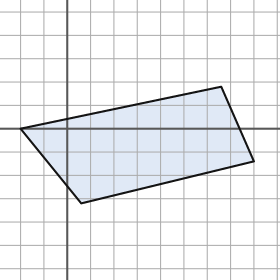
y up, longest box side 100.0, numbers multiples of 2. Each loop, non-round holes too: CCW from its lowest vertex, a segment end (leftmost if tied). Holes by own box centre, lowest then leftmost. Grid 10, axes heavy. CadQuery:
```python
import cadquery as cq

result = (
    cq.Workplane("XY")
    .moveTo(6.0, -32.0)
    .lineTo(80.0, -14.0)
    .lineTo(66.0, 18.0)
    .lineTo(-20.0, 0.0)
    .close()
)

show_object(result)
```